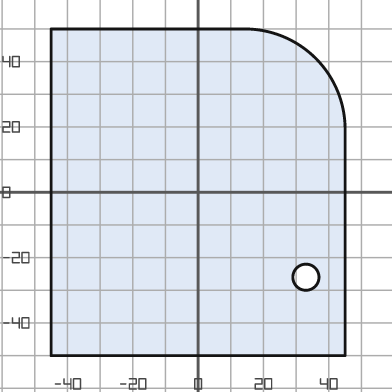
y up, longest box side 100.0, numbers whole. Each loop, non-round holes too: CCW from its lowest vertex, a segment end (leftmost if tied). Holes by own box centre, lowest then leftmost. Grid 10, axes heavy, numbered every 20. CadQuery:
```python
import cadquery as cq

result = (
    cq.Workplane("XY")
    .moveTo(-45.0, -50.0)
    .lineTo(45.0, -50.0)
    .lineTo(45.0, 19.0)
    .threePointArc((36.0, 41.0), (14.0, 50.0))
    .lineTo(-45.0, 50.0)
    .close()
    .moveTo(33.0, -26.0)
    .circle(4.0)
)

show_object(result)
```